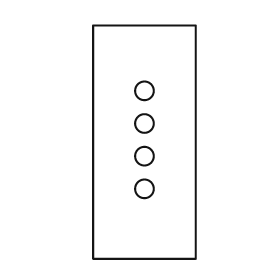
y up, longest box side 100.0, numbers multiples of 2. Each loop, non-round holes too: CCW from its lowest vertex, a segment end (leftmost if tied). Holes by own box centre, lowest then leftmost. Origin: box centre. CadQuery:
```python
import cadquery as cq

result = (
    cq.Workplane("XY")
    .moveTo(-22.0, -50.0)
    .lineTo(22.0, -50.0)
    .lineTo(22.0, 50.0)
    .lineTo(-22.0, 50.0)
    .close()
    .moveTo(0.0, -20.0)
    .circle(4.0)
    .moveTo(0.0, -6.0)
    .circle(4.0)
    .moveTo(0.0, 8.0)
    .circle(4.0)
    .moveTo(0.0, 22.0)
    .circle(4.0)
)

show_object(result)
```